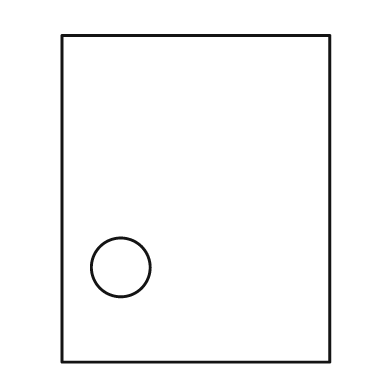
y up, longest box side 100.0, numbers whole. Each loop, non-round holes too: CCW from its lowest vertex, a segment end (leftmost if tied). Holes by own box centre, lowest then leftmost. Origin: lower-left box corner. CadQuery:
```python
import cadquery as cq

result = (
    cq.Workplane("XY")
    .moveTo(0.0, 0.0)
    .lineTo(82.0, 0.0)
    .lineTo(82.0, 100.0)
    .lineTo(0.0, 100.0)
    .close()
    .moveTo(18.0, 29.0)
    .circle(9.0)
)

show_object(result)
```